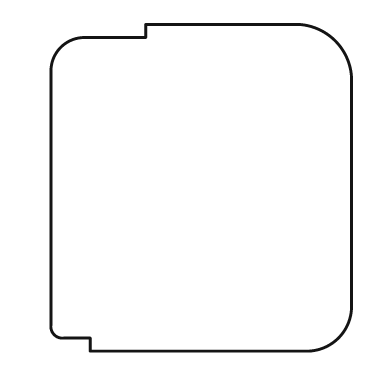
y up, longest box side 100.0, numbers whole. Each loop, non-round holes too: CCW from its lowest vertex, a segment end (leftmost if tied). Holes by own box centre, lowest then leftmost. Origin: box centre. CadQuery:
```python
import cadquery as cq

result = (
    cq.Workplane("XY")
    .moveTo(-34.0, -50.0)
    .lineTo(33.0, -50.0)
    .threePointArc((42.0, -46.0), (46.0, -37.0))
    .lineTo(46.0, 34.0)
    .threePointArc((41.0, 45.0), (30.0, 50.0))
    .lineTo(-17.0, 50.0)
    .lineTo(-17.0, 46.0)
    .lineTo(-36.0, 46.0)
    .threePointArc((-43.0, 43.0), (-46.0, 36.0))
    .lineTo(-46.0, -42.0)
    .threePointArc((-45.0, -45.0), (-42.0, -46.0))
    .lineTo(-34.0, -46.0)
    .close()
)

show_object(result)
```